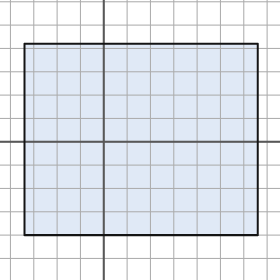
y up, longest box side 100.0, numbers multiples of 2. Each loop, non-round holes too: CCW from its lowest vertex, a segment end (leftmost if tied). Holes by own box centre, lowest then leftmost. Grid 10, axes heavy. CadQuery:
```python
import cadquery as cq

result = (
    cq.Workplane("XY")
    .moveTo(-34.0, -40.0)
    .lineTo(66.0, -40.0)
    .lineTo(66.0, 42.0)
    .lineTo(-34.0, 42.0)
    .close()
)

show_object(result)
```